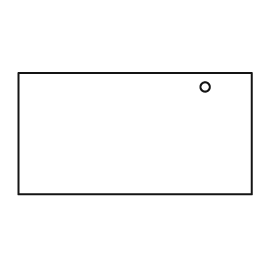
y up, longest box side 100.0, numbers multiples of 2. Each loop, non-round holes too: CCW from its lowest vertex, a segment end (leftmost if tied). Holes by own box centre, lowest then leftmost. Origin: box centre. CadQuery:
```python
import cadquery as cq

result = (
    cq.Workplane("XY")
    .moveTo(-50.0, -26.0)
    .lineTo(50.0, -26.0)
    .lineTo(50.0, 26.0)
    .lineTo(-50.0, 26.0)
    .close()
    .moveTo(30.0, 20.0)
    .circle(2.0)
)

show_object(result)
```